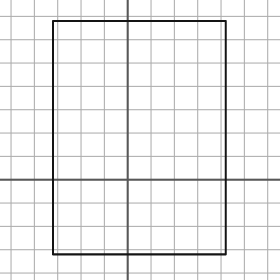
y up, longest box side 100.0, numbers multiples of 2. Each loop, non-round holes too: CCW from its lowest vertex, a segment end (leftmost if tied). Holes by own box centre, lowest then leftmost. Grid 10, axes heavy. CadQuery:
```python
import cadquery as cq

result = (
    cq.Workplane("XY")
    .moveTo(-32.0, -32.0)
    .lineTo(42.0, -32.0)
    .lineTo(42.0, 68.0)
    .lineTo(-32.0, 68.0)
    .close()
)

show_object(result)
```